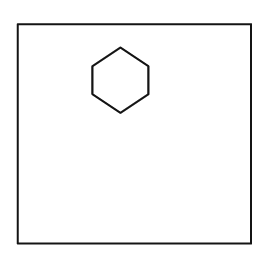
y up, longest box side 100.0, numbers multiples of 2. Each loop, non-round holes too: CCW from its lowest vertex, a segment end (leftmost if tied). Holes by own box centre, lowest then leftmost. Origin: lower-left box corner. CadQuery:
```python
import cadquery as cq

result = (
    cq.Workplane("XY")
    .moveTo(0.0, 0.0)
    .lineTo(100.0, 0.0)
    .lineTo(100.0, 94.0)
    .lineTo(0.0, 94.0)
    .close()
    .moveTo(44.0, 56.0)
    .lineTo(56.0, 64.0)
    .lineTo(56.0, 76.0)
    .lineTo(44.0, 84.0)
    .lineTo(32.0, 76.0)
    .lineTo(32.0, 64.0)
    .close()
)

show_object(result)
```